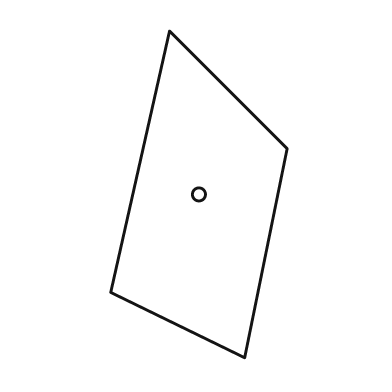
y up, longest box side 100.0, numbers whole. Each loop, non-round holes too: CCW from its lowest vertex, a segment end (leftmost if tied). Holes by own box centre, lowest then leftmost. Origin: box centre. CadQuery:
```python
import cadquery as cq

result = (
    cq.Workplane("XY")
    .moveTo(14.0, -50.0)
    .lineTo(27.0, 14.0)
    .lineTo(-9.0, 50.0)
    .lineTo(-27.0, -30.0)
    .close()
    .moveTo(0.0, 0.0)
    .circle(2.0)
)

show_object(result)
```